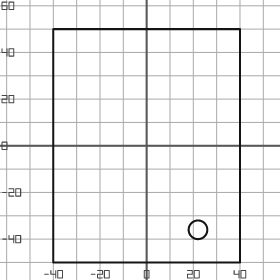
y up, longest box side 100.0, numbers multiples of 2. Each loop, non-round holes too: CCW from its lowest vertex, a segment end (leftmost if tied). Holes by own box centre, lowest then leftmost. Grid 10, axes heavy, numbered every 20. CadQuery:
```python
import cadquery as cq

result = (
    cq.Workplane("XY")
    .moveTo(-40.0, -50.0)
    .lineTo(40.0, -50.0)
    .lineTo(40.0, 50.0)
    .lineTo(-40.0, 50.0)
    .close()
    .moveTo(22.0, -36.0)
    .circle(4.0)
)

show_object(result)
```